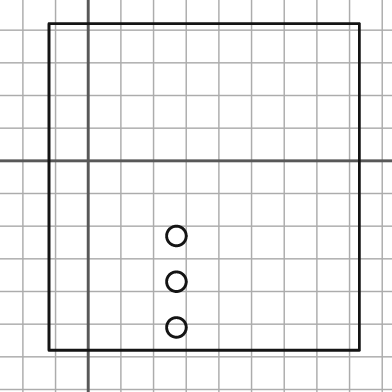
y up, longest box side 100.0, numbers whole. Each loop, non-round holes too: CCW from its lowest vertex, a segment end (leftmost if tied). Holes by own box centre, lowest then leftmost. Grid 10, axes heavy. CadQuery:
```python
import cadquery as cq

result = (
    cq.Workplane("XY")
    .moveTo(-12.0, -58.0)
    .lineTo(83.0, -58.0)
    .lineTo(83.0, 42.0)
    .lineTo(-12.0, 42.0)
    .close()
    .moveTo(27.0, -51.0)
    .circle(3.0)
    .moveTo(27.0, -37.0)
    .circle(3.0)
    .moveTo(27.0, -23.0)
    .circle(3.0)
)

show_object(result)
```